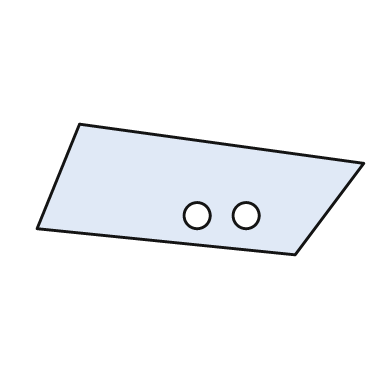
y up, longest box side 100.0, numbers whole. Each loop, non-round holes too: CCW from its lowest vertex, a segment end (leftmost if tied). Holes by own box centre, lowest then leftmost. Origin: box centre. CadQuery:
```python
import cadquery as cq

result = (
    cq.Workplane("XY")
    .moveTo(29.0, -20.0)
    .lineTo(50.0, 8.0)
    .lineTo(-37.0, 20.0)
    .lineTo(-50.0, -12.0)
    .close()
    .moveTo(-1.0, -8.0)
    .circle(4.0)
    .moveTo(14.0, -8.0)
    .circle(4.0)
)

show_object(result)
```